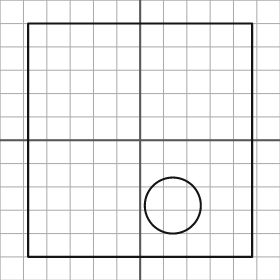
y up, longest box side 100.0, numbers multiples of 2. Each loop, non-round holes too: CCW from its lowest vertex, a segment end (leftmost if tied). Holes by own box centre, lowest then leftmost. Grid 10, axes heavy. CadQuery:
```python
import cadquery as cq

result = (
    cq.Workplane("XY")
    .moveTo(-48.0, -50.0)
    .lineTo(48.0, -50.0)
    .lineTo(48.0, 50.0)
    .lineTo(-48.0, 50.0)
    .close()
    .moveTo(14.0, -28.0)
    .circle(12.0)
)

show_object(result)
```